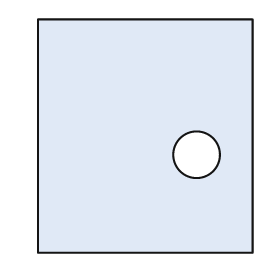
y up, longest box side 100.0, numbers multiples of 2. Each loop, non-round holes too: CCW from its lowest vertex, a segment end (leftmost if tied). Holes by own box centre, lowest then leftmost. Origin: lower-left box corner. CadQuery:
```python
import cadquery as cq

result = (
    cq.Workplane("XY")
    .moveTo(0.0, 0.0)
    .lineTo(92.0, 0.0)
    .lineTo(92.0, 100.0)
    .lineTo(0.0, 100.0)
    .close()
    .moveTo(68.0, 42.0)
    .circle(10.0)
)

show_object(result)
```